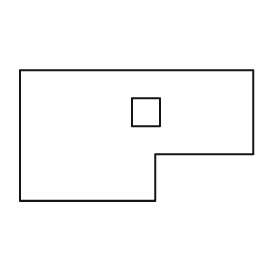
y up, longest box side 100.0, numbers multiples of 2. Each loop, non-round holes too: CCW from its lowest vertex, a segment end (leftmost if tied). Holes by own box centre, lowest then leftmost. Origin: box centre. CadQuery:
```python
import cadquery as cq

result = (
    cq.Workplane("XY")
    .moveTo(-50.0, -28.0)
    .lineTo(8.0, -28.0)
    .lineTo(8.0, -8.0)
    .lineTo(50.0, -8.0)
    .lineTo(50.0, 28.0)
    .lineTo(-50.0, 28.0)
    .close()
    .moveTo(-2.0, 4.0)
    .lineTo(10.0, 4.0)
    .lineTo(10.0, 16.0)
    .lineTo(-2.0, 16.0)
    .close()
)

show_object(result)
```